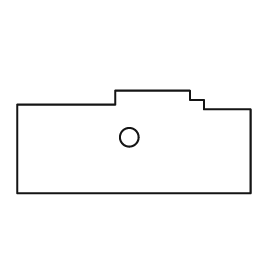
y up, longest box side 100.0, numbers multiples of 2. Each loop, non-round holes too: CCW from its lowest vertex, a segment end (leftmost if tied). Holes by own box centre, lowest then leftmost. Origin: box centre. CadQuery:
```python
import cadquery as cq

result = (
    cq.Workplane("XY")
    .moveTo(-50.0, -22.0)
    .lineTo(50.0, -22.0)
    .lineTo(50.0, 14.0)
    .lineTo(30.0, 14.0)
    .lineTo(30.0, 18.0)
    .lineTo(24.0, 18.0)
    .lineTo(24.0, 22.0)
    .lineTo(-8.0, 22.0)
    .lineTo(-8.0, 16.0)
    .lineTo(-50.0, 16.0)
    .close()
    .moveTo(-2.0, 2.0)
    .circle(4.0)
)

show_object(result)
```